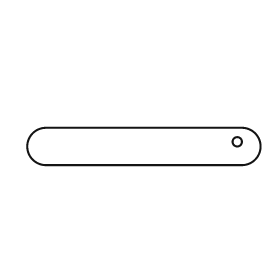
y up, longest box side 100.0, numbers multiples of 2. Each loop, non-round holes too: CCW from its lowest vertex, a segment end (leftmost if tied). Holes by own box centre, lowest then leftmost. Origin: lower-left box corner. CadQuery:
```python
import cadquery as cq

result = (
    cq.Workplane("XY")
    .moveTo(8.0, 0.0)
    .lineTo(92.0, 0.0)
    .threePointArc((100.0, 8.0), (92.0, 16.0))
    .lineTo(8.0, 16.0)
    .threePointArc((0.0, 8.0), (8.0, 0.0))
    .close()
    .moveTo(90.0, 10.0)
    .circle(2.0)
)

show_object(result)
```